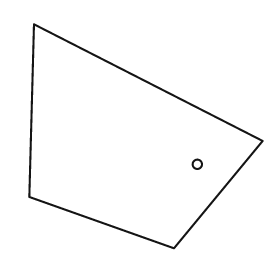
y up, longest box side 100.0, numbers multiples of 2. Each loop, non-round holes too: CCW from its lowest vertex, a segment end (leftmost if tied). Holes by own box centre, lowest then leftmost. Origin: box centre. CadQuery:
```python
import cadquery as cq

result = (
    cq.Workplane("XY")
    .moveTo(12.0, -48.0)
    .lineTo(50.0, -2.0)
    .lineTo(-48.0, 48.0)
    .lineTo(-50.0, -26.0)
    .close()
    .moveTo(22.0, -12.0)
    .circle(2.0)
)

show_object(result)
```